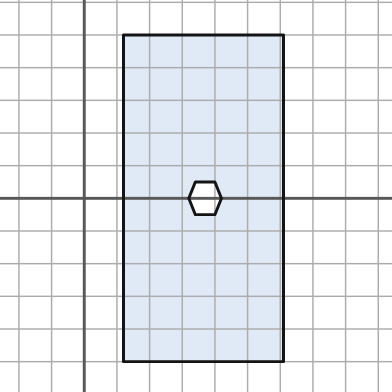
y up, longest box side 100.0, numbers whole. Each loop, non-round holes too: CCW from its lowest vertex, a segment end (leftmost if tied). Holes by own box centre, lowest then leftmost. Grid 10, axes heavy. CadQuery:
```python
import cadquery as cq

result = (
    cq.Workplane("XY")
    .moveTo(12.0, -50.0)
    .lineTo(61.0, -50.0)
    .lineTo(61.0, 50.0)
    .lineTo(12.0, 50.0)
    .close()
    .moveTo(34.0, -5.0)
    .lineTo(40.0, -5.0)
    .lineTo(42.0, 0.0)
    .lineTo(40.0, 5.0)
    .lineTo(34.0, 5.0)
    .lineTo(32.0, 0.0)
    .close()
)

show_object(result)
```